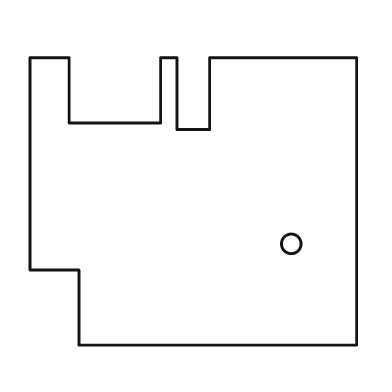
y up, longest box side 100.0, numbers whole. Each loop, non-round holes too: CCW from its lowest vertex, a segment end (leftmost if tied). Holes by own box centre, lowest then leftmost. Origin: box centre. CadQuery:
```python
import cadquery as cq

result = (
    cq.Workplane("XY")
    .moveTo(-35.0, -44.0)
    .lineTo(50.0, -44.0)
    .lineTo(50.0, 44.0)
    .lineTo(5.0, 44.0)
    .lineTo(5.0, 22.0)
    .lineTo(-5.0, 22.0)
    .lineTo(-5.0, 44.0)
    .lineTo(-10.0, 44.0)
    .lineTo(-10.0, 24.0)
    .lineTo(-38.0, 24.0)
    .lineTo(-38.0, 44.0)
    .lineTo(-50.0, 44.0)
    .lineTo(-50.0, -21.0)
    .lineTo(-35.0, -21.0)
    .close()
    .moveTo(30.0, -13.0)
    .circle(3.0)
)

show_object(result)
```